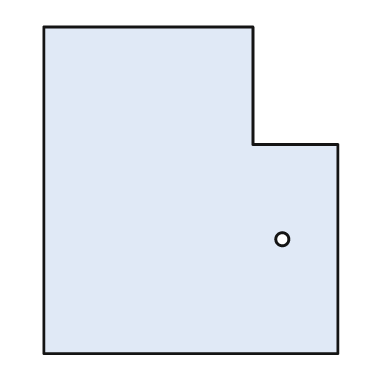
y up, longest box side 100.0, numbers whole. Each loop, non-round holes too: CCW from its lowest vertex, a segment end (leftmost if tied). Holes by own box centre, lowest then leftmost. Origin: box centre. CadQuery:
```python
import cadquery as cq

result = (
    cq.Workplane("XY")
    .moveTo(-45.0, -50.0)
    .lineTo(45.0, -50.0)
    .lineTo(45.0, 14.0)
    .lineTo(19.0, 14.0)
    .lineTo(19.0, 50.0)
    .lineTo(-45.0, 50.0)
    .close()
    .moveTo(28.0, -15.0)
    .circle(2.0)
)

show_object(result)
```